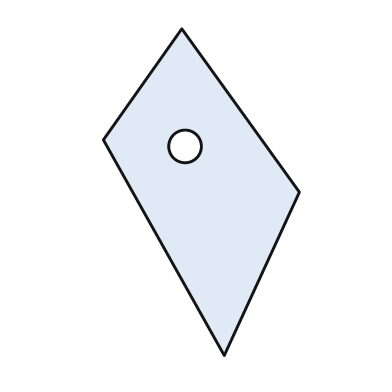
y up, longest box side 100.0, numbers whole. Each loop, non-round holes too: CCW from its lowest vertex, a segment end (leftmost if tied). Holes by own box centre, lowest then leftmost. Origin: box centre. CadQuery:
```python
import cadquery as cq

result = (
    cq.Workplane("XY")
    .moveTo(7.0, -50.0)
    .lineTo(30.0, 0.0)
    .lineTo(-6.0, 50.0)
    .lineTo(-30.0, 16.0)
    .close()
    .moveTo(-5.0, 14.0)
    .circle(5.0)
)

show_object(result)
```